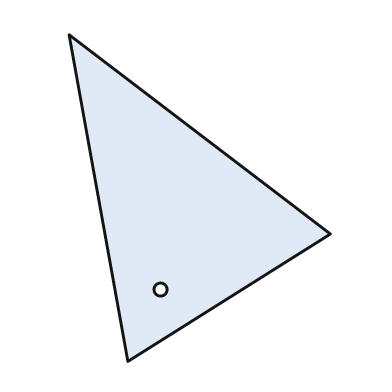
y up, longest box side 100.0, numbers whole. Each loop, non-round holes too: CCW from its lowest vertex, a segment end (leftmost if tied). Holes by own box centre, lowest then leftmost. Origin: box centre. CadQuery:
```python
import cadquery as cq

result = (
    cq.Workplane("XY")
    .moveTo(-22.0, -50.0)
    .lineTo(40.0, -11.0)
    .lineTo(-40.0, 50.0)
    .close()
    .moveTo(-12.0, -28.0)
    .circle(2.0)
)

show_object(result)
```